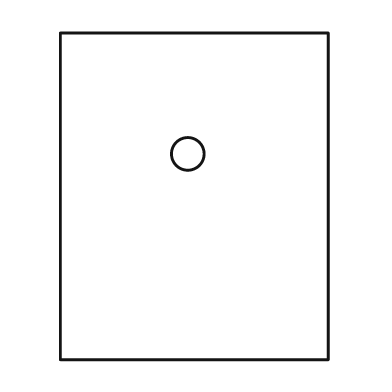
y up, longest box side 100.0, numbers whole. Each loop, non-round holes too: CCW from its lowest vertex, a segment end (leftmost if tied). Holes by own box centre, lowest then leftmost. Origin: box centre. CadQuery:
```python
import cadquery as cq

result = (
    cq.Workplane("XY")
    .moveTo(-41.0, -50.0)
    .lineTo(41.0, -50.0)
    .lineTo(41.0, 50.0)
    .lineTo(-41.0, 50.0)
    .close()
    .moveTo(-2.0, 13.0)
    .circle(5.0)
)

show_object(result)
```